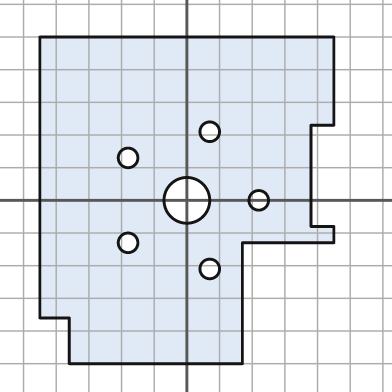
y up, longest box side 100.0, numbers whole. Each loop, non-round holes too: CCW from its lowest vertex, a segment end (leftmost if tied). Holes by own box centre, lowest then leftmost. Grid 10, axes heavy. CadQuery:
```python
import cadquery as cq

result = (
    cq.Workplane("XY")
    .moveTo(-36.0, -50.0)
    .lineTo(17.0, -50.0)
    .lineTo(17.0, -13.0)
    .lineTo(45.0, -13.0)
    .lineTo(45.0, -8.0)
    .lineTo(38.0, -8.0)
    .lineTo(38.0, 23.0)
    .lineTo(45.0, 23.0)
    .lineTo(45.0, 50.0)
    .lineTo(-45.0, 50.0)
    .lineTo(-45.0, -36.0)
    .lineTo(-36.0, -36.0)
    .close()
    .moveTo(7.0, -21.0)
    .circle(3.0)
    .moveTo(-18.0, -13.0)
    .circle(3.0)
    .moveTo(0.0, 0.0)
    .circle(7.0)
    .moveTo(22.0, 0.0)
    .circle(3.0)
    .moveTo(-18.0, 13.0)
    .circle(3.0)
    .moveTo(7.0, 21.0)
    .circle(3.0)
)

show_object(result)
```